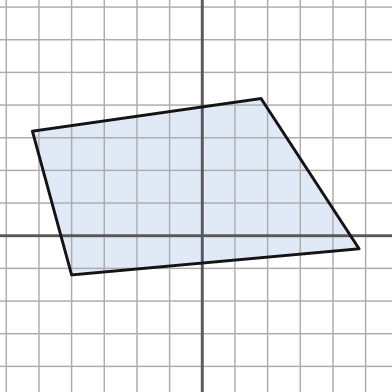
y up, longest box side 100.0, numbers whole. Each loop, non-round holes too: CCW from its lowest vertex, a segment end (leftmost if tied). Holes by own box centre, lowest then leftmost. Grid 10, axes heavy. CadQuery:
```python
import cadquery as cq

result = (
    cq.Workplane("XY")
    .moveTo(-40.0, -12.0)
    .lineTo(48.0, -4.0)
    .lineTo(18.0, 42.0)
    .lineTo(-52.0, 32.0)
    .close()
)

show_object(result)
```